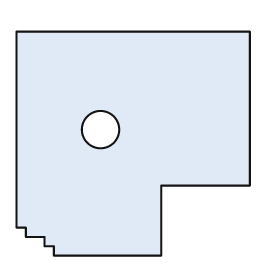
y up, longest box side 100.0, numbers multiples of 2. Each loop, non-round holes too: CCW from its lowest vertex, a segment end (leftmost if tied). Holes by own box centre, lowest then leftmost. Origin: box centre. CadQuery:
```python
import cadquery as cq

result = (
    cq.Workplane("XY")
    .moveTo(-34.0, -48.0)
    .lineTo(12.0, -48.0)
    .lineTo(12.0, -18.0)
    .lineTo(50.0, -18.0)
    .lineTo(50.0, 48.0)
    .lineTo(-50.0, 48.0)
    .lineTo(-50.0, -36.0)
    .lineTo(-46.0, -36.0)
    .lineTo(-46.0, -40.0)
    .lineTo(-38.0, -40.0)
    .lineTo(-38.0, -44.0)
    .lineTo(-34.0, -44.0)
    .close()
    .moveTo(-14.0, 6.0)
    .circle(8.0)
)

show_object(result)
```